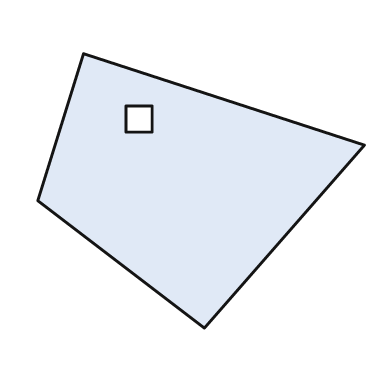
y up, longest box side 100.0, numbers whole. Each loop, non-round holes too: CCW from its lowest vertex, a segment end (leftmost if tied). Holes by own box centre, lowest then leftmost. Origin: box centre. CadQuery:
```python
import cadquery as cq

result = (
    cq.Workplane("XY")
    .moveTo(1.0, -42.0)
    .lineTo(50.0, 14.0)
    .lineTo(-36.0, 42.0)
    .lineTo(-50.0, -3.0)
    .close()
    .moveTo(-23.0, 18.0)
    .lineTo(-15.0, 18.0)
    .lineTo(-15.0, 26.0)
    .lineTo(-23.0, 26.0)
    .close()
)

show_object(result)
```